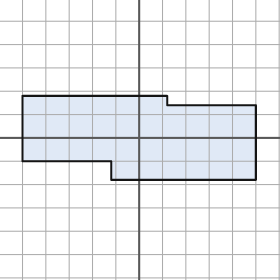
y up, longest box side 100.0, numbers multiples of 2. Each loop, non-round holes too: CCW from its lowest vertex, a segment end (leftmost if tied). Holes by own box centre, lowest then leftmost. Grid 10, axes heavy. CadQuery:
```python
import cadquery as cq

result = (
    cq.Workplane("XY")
    .moveTo(-12.0, -18.0)
    .lineTo(50.0, -18.0)
    .lineTo(50.0, 14.0)
    .lineTo(12.0, 14.0)
    .lineTo(12.0, 18.0)
    .lineTo(-50.0, 18.0)
    .lineTo(-50.0, -10.0)
    .lineTo(-12.0, -10.0)
    .close()
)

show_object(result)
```